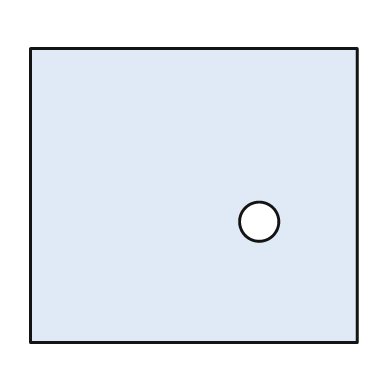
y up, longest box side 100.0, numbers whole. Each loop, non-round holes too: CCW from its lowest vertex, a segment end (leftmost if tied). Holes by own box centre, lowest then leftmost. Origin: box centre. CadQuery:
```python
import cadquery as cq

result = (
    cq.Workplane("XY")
    .moveTo(-50.0, -45.0)
    .lineTo(50.0, -45.0)
    .lineTo(50.0, 45.0)
    .lineTo(-50.0, 45.0)
    .close()
    .moveTo(20.0, -8.0)
    .circle(6.0)
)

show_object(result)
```